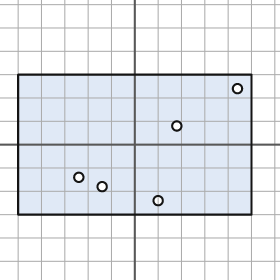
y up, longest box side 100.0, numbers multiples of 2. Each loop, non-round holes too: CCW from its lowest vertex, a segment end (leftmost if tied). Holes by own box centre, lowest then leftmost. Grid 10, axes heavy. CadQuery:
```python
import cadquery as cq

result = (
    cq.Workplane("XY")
    .moveTo(-50.0, -30.0)
    .lineTo(50.0, -30.0)
    .lineTo(50.0, 30.0)
    .lineTo(-50.0, 30.0)
    .close()
    .moveTo(10.0, -24.0)
    .circle(2.0)
    .moveTo(-14.0, -18.0)
    .circle(2.0)
    .moveTo(-24.0, -14.0)
    .circle(2.0)
    .moveTo(18.0, 8.0)
    .circle(2.0)
    .moveTo(44.0, 24.0)
    .circle(2.0)
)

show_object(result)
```